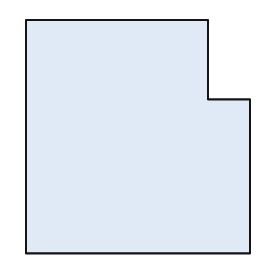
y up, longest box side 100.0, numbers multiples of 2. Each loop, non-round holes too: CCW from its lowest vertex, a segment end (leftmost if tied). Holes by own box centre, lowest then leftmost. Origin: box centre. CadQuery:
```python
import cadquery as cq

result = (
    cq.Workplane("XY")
    .moveTo(-48.0, -50.0)
    .lineTo(48.0, -50.0)
    .lineTo(48.0, 16.0)
    .lineTo(30.0, 16.0)
    .lineTo(30.0, 50.0)
    .lineTo(-48.0, 50.0)
    .close()
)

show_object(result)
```